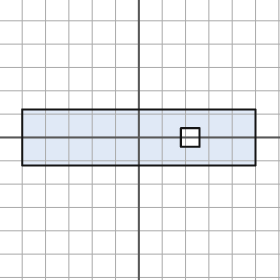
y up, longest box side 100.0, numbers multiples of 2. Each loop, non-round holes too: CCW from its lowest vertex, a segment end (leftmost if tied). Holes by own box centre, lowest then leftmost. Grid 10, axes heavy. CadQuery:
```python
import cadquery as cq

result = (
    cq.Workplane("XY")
    .moveTo(-50.0, -12.0)
    .lineTo(50.0, -12.0)
    .lineTo(50.0, 12.0)
    .lineTo(-50.0, 12.0)
    .close()
    .moveTo(18.0, -4.0)
    .lineTo(26.0, -4.0)
    .lineTo(26.0, 4.0)
    .lineTo(18.0, 4.0)
    .close()
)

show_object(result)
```